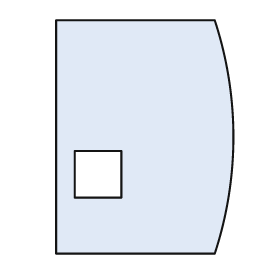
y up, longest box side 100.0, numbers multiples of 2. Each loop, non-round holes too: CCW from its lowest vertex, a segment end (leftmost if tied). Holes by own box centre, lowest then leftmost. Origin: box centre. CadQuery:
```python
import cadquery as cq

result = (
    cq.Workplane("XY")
    .moveTo(-38.0, -50.0)
    .lineTo(30.0, -50.0)
    .threePointArc((38.0, 0.0), (30.0, 50.0))
    .lineTo(-38.0, 50.0)
    .close()
    .moveTo(-30.0, -26.0)
    .lineTo(-10.0, -26.0)
    .lineTo(-10.0, -6.0)
    .lineTo(-30.0, -6.0)
    .close()
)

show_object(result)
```